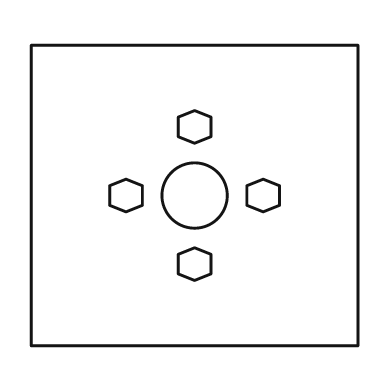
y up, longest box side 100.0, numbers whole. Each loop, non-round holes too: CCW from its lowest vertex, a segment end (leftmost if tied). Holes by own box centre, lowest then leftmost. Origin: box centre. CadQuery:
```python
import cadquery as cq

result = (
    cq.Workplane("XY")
    .moveTo(-50.0, -46.0)
    .lineTo(50.0, -46.0)
    .lineTo(50.0, 46.0)
    .lineTo(-50.0, 46.0)
    .close()
    .moveTo(0.0, -26.0)
    .lineTo(5.0, -24.0)
    .lineTo(5.0, -18.0)
    .lineTo(0.0, -16.0)
    .lineTo(-5.0, -18.0)
    .lineTo(-5.0, -24.0)
    .close()
    .moveTo(-21.0, -5.0)
    .lineTo(-16.0, -3.0)
    .lineTo(-16.0, 3.0)
    .lineTo(-21.0, 5.0)
    .lineTo(-26.0, 3.0)
    .lineTo(-26.0, -3.0)
    .close()
    .moveTo(0.0, 0.0)
    .circle(10.0)
    .moveTo(21.0, -5.0)
    .lineTo(26.0, -3.0)
    .lineTo(26.0, 3.0)
    .lineTo(21.0, 5.0)
    .lineTo(16.0, 3.0)
    .lineTo(16.0, -3.0)
    .close()
    .moveTo(0.0, 16.0)
    .lineTo(5.0, 18.0)
    .lineTo(5.0, 24.0)
    .lineTo(0.0, 26.0)
    .lineTo(-5.0, 24.0)
    .lineTo(-5.0, 18.0)
    .close()
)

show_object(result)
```